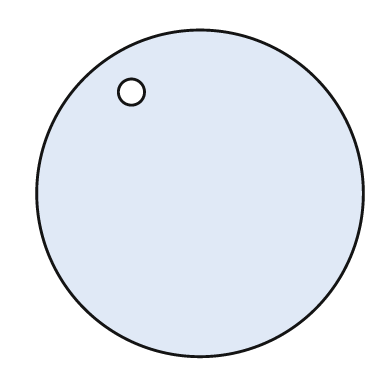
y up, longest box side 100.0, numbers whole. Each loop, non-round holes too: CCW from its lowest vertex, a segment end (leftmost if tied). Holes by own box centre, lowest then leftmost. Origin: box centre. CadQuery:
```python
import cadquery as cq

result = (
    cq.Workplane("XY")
    .moveTo(0.0, 0.0)
    .circle(50.0)
    .moveTo(-21.0, 31.0)
    .circle(4.0)
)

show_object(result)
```